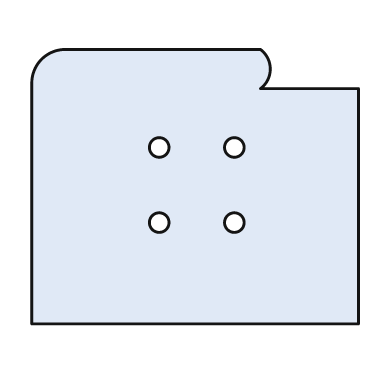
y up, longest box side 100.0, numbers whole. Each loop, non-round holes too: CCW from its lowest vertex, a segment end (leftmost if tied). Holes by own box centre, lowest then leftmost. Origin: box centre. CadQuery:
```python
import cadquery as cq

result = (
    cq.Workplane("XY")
    .moveTo(-50.0, -42.0)
    .lineTo(50.0, -42.0)
    .lineTo(50.0, 30.0)
    .lineTo(20.0, 30.0)
    .threePointArc((23.0, 36.0), (20.0, 42.0))
    .lineTo(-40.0, 42.0)
    .threePointArc((-47.0, 39.0), (-50.0, 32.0))
    .close()
    .moveTo(-11.0, -11.0)
    .circle(3.0)
    .moveTo(12.0, -11.0)
    .circle(3.0)
    .moveTo(-11.0, 12.0)
    .circle(3.0)
    .moveTo(12.0, 12.0)
    .circle(3.0)
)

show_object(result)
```